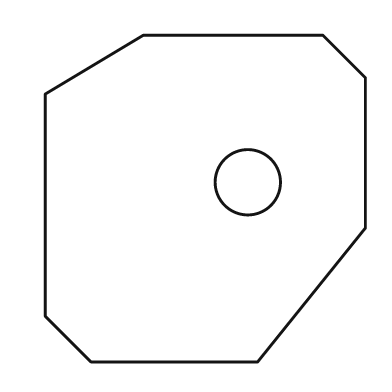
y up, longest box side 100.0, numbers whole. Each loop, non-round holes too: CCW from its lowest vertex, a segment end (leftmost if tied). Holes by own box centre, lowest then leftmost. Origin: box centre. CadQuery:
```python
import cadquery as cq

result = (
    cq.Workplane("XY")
    .moveTo(-35.0, -50.0)
    .lineTo(16.0, -50.0)
    .lineTo(49.0, -9.0)
    .lineTo(49.0, 37.0)
    .lineTo(36.0, 50.0)
    .lineTo(-19.0, 50.0)
    .lineTo(-49.0, 32.0)
    .lineTo(-49.0, -36.0)
    .close()
    .moveTo(13.0, 5.0)
    .circle(10.0)
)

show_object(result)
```